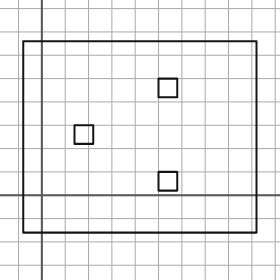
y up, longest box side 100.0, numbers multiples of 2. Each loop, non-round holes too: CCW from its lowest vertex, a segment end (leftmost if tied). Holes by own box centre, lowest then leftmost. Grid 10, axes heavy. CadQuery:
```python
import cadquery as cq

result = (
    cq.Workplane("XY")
    .moveTo(-8.0, -16.0)
    .lineTo(92.0, -16.0)
    .lineTo(92.0, 66.0)
    .lineTo(-8.0, 66.0)
    .close()
    .moveTo(50.0, 2.0)
    .lineTo(58.0, 2.0)
    .lineTo(58.0, 10.0)
    .lineTo(50.0, 10.0)
    .close()
    .moveTo(14.0, 22.0)
    .lineTo(22.0, 22.0)
    .lineTo(22.0, 30.0)
    .lineTo(14.0, 30.0)
    .close()
    .moveTo(50.0, 42.0)
    .lineTo(58.0, 42.0)
    .lineTo(58.0, 50.0)
    .lineTo(50.0, 50.0)
    .close()
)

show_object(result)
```